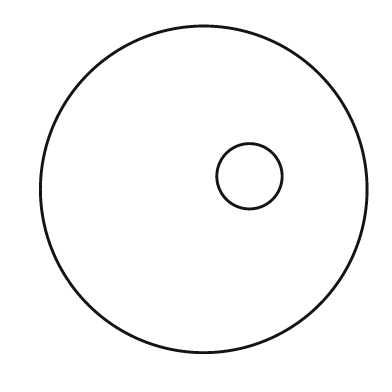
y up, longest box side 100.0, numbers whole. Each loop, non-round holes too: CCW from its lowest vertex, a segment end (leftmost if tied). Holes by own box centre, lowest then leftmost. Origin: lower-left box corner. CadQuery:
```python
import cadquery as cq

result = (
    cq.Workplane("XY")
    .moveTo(50.0, 50.0)
    .circle(50.0)
    .moveTo(64.0, 54.0)
    .circle(10.0)
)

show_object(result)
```